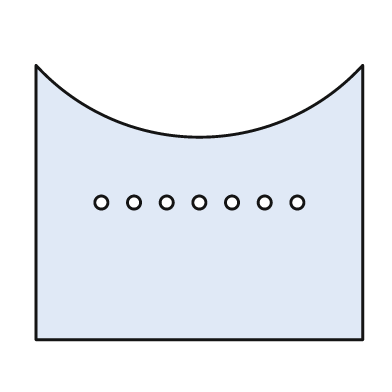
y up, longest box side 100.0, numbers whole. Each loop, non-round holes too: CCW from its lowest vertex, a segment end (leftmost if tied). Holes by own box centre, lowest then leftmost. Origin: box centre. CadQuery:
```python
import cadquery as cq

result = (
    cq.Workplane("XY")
    .moveTo(-50.0, -42.0)
    .lineTo(50.0, -42.0)
    .lineTo(50.0, 42.0)
    .threePointArc((0.0, 20.0), (-50.0, 42.0))
    .close()
    .moveTo(-30.0, 0.0)
    .circle(2.0)
    .moveTo(-20.0, 0.0)
    .circle(2.0)
    .moveTo(-10.0, 0.0)
    .circle(2.0)
    .moveTo(0.0, 0.0)
    .circle(2.0)
    .moveTo(10.0, 0.0)
    .circle(2.0)
    .moveTo(20.0, 0.0)
    .circle(2.0)
    .moveTo(30.0, 0.0)
    .circle(2.0)
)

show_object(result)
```